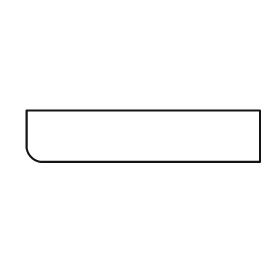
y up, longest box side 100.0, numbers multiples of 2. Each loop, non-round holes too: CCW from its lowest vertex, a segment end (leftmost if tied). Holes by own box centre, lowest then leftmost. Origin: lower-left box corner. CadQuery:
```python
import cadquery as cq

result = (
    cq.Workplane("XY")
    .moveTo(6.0, 0.0)
    .lineTo(100.0, 0.0)
    .lineTo(100.0, 22.0)
    .lineTo(0.0, 22.0)
    .lineTo(0.0, 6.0)
    .threePointArc((2.0, 2.0), (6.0, 0.0))
    .close()
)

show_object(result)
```